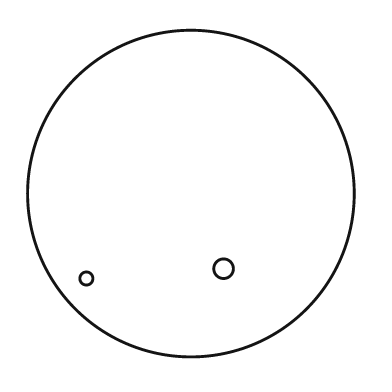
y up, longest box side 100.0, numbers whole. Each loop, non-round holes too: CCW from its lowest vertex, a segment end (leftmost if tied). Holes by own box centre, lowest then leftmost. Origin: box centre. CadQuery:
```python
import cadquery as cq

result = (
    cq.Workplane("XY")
    .moveTo(0.0, 0.0)
    .circle(50.0)
    .moveTo(-32.0, -26.0)
    .circle(2.0)
    .moveTo(10.0, -23.0)
    .circle(3.0)
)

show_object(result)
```